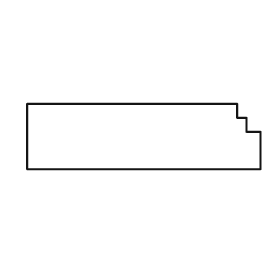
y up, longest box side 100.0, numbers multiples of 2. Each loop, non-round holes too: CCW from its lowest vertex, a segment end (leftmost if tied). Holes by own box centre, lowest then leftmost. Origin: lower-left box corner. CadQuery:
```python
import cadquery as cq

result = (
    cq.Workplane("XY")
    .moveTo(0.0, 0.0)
    .lineTo(100.0, 0.0)
    .lineTo(100.0, 16.0)
    .lineTo(94.0, 16.0)
    .lineTo(94.0, 22.0)
    .lineTo(90.0, 22.0)
    .lineTo(90.0, 28.0)
    .lineTo(0.0, 28.0)
    .close()
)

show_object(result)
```